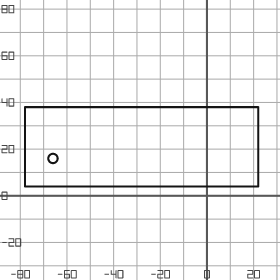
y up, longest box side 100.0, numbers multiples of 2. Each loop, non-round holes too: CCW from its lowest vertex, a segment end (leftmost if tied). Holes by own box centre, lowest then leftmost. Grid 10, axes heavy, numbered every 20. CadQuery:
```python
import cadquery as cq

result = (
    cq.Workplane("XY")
    .moveTo(-78.0, 4.0)
    .lineTo(22.0, 4.0)
    .lineTo(22.0, 38.0)
    .lineTo(-78.0, 38.0)
    .close()
    .moveTo(-66.0, 16.0)
    .circle(2.0)
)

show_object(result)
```